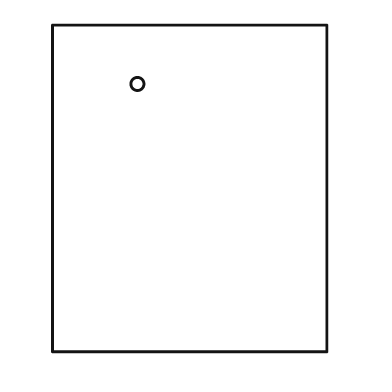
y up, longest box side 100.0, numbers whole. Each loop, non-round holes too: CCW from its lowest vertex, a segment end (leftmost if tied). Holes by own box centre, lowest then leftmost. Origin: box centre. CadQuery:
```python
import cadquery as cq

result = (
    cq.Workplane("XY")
    .moveTo(-42.0, -50.0)
    .lineTo(42.0, -50.0)
    .lineTo(42.0, 50.0)
    .lineTo(-42.0, 50.0)
    .close()
    .moveTo(-16.0, 32.0)
    .circle(2.0)
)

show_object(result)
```